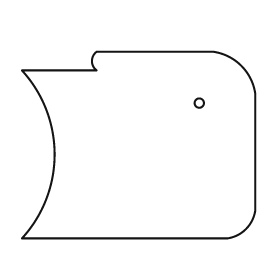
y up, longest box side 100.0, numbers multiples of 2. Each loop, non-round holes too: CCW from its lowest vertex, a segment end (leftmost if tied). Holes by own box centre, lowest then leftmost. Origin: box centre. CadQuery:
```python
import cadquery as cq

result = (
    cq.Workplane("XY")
    .moveTo(-50.0, -40.0)
    .lineTo(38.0, -40.0)
    .threePointArc((46.0, -36.0), (50.0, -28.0))
    .lineTo(50.0, 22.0)
    .threePointArc((44.0, 34.0), (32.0, 40.0))
    .lineTo(-18.0, 40.0)
    .threePointArc((-20.0, 36.0), (-18.0, 32.0))
    .lineTo(-50.0, 32.0)
    .threePointArc((-36.0, -4.0), (-50.0, -40.0))
    .close()
    .moveTo(26.0, 18.0)
    .circle(2.0)
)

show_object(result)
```